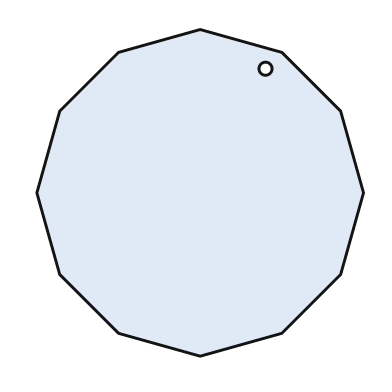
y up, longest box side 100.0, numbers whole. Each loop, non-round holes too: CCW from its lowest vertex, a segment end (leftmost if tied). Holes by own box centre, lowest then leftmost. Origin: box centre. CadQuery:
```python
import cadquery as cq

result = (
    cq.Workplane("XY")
    .moveTo(0.0, -50.0)
    .lineTo(25.0, -43.0)
    .lineTo(43.0, -25.0)
    .lineTo(50.0, 0.0)
    .lineTo(43.0, 25.0)
    .lineTo(25.0, 43.0)
    .lineTo(0.0, 50.0)
    .lineTo(-25.0, 43.0)
    .lineTo(-43.0, 25.0)
    .lineTo(-50.0, 0.0)
    .lineTo(-43.0, -25.0)
    .lineTo(-25.0, -43.0)
    .close()
    .moveTo(20.0, 38.0)
    .circle(2.0)
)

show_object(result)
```